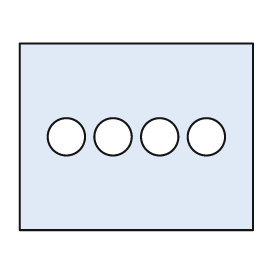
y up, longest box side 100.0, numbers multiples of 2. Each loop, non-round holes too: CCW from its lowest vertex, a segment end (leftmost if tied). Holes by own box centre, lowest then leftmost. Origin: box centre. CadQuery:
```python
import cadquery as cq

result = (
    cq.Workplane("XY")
    .moveTo(-50.0, -40.0)
    .lineTo(50.0, -40.0)
    .lineTo(50.0, 40.0)
    .lineTo(-50.0, 40.0)
    .close()
    .moveTo(-30.0, 0.0)
    .circle(8.0)
    .moveTo(-10.0, 0.0)
    .circle(8.0)
    .moveTo(10.0, 0.0)
    .circle(8.0)
    .moveTo(30.0, 0.0)
    .circle(8.0)
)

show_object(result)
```